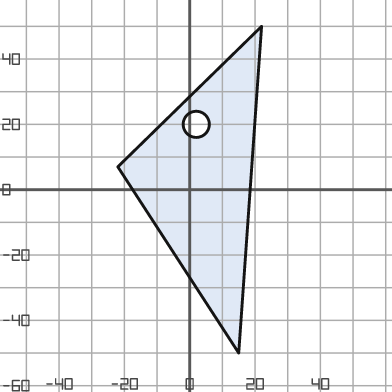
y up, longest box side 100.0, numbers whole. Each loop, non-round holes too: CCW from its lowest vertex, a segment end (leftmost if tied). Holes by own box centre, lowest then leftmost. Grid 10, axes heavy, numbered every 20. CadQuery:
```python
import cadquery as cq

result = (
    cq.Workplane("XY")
    .moveTo(15.0, -50.0)
    .lineTo(22.0, 50.0)
    .lineTo(-22.0, 7.0)
    .close()
    .moveTo(2.0, 20.0)
    .circle(4.0)
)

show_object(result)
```